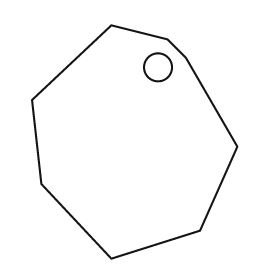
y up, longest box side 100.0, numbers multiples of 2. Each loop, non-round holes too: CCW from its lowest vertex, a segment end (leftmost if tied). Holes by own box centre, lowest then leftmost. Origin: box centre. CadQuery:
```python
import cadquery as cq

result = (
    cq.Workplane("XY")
    .moveTo(-10.0, -50.0)
    .lineTo(28.0, -38.0)
    .lineTo(44.0, -2.0)
    .lineTo(22.0, 36.0)
    .lineTo(14.0, 44.0)
    .lineTo(-10.0, 50.0)
    .lineTo(-44.0, 18.0)
    .lineTo(-40.0, -18.0)
    .close()
    .moveTo(10.0, 32.0)
    .circle(6.0)
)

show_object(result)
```